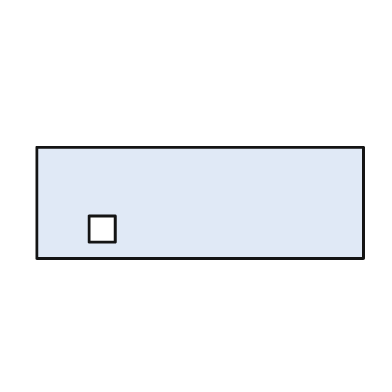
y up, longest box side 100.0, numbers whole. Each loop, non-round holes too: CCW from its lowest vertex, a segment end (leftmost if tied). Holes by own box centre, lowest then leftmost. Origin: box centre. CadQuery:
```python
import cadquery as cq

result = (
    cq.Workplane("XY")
    .moveTo(-50.0, -17.0)
    .lineTo(50.0, -17.0)
    .lineTo(50.0, 17.0)
    .lineTo(-50.0, 17.0)
    .close()
    .moveTo(-34.0, -12.0)
    .lineTo(-26.0, -12.0)
    .lineTo(-26.0, -4.0)
    .lineTo(-34.0, -4.0)
    .close()
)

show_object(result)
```